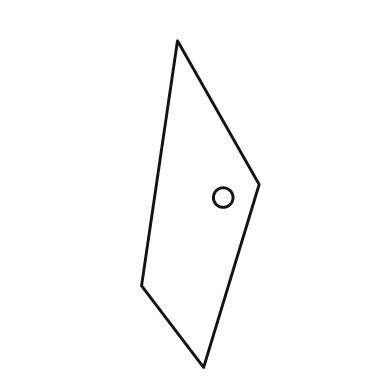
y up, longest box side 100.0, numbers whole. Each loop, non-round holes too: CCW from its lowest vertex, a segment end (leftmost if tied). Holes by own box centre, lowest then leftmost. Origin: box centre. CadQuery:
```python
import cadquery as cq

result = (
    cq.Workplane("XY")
    .moveTo(1.0, -50.0)
    .lineTo(18.0, 6.0)
    .lineTo(-7.0, 50.0)
    .lineTo(-18.0, -25.0)
    .close()
    .moveTo(7.0, 2.0)
    .circle(3.0)
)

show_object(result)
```